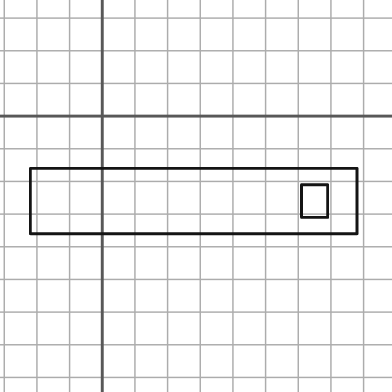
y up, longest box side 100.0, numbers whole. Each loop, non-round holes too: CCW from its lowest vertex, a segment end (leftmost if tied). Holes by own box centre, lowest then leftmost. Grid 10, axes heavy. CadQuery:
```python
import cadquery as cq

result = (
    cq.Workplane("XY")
    .moveTo(-22.0, -36.0)
    .lineTo(78.0, -36.0)
    .lineTo(78.0, -16.0)
    .lineTo(-22.0, -16.0)
    .close()
    .moveTo(61.0, -31.0)
    .lineTo(69.0, -31.0)
    .lineTo(69.0, -21.0)
    .lineTo(61.0, -21.0)
    .close()
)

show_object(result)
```